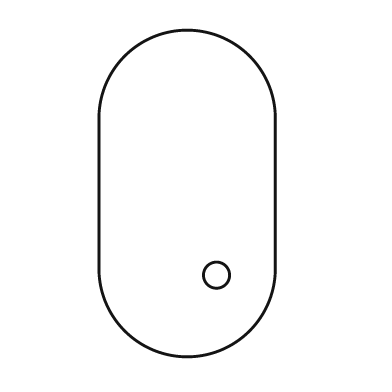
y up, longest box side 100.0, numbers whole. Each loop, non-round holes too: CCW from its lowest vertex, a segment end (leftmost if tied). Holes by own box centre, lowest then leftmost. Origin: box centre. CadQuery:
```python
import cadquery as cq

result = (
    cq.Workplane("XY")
    .moveTo(-27.0, -23.0)
    .threePointArc((0.0, -50.0), (27.0, -23.0))
    .lineTo(27.0, 23.0)
    .threePointArc((0.0, 50.0), (-27.0, 23.0))
    .close()
    .moveTo(9.0, -25.0)
    .circle(4.0)
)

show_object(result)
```